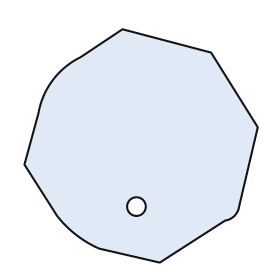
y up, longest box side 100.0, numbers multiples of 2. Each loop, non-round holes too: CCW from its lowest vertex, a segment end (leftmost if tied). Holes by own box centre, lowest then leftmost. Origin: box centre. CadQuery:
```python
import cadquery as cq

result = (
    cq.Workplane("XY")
    .moveTo(8.0, -50.0)
    .lineTo(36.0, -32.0)
    .threePointArc((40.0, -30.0), (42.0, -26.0))
    .lineTo(50.0, 8.0)
    .lineTo(30.0, 40.0)
    .lineTo(-8.0, 50.0)
    .lineTo(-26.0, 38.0)
    .threePointArc((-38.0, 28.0), (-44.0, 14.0))
    .lineTo(-50.0, -8.0)
    .lineTo(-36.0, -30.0)
    .threePointArc((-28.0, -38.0), (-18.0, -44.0))
    .close()
    .moveTo(-2.0, -26.0)
    .circle(4.0)
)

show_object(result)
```